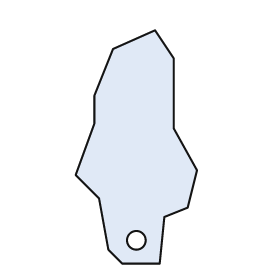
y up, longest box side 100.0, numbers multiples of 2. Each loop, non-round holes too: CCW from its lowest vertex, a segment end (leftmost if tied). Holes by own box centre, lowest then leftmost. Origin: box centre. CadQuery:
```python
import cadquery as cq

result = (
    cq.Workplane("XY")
    .moveTo(-6.0, -50.0)
    .lineTo(10.0, -50.0)
    .lineTo(12.0, -30.0)
    .lineTo(22.0, -26.0)
    .lineTo(26.0, -10.0)
    .lineTo(16.0, 8.0)
    .lineTo(16.0, 38.0)
    .lineTo(8.0, 50.0)
    .lineTo(-10.0, 42.0)
    .lineTo(-18.0, 22.0)
    .lineTo(-18.0, 10.0)
    .lineTo(-26.0, -12.0)
    .lineTo(-16.0, -22.0)
    .lineTo(-12.0, -44.0)
    .close()
    .moveTo(0.0, -40.0)
    .circle(4.0)
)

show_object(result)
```